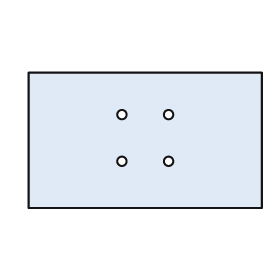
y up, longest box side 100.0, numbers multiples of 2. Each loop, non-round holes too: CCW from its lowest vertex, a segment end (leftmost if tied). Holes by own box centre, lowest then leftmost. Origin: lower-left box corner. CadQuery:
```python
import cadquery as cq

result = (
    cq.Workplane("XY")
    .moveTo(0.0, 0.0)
    .lineTo(100.0, 0.0)
    .lineTo(100.0, 58.0)
    .lineTo(0.0, 58.0)
    .close()
    .moveTo(40.0, 20.0)
    .circle(2.0)
    .moveTo(60.0, 20.0)
    .circle(2.0)
    .moveTo(40.0, 40.0)
    .circle(2.0)
    .moveTo(60.0, 40.0)
    .circle(2.0)
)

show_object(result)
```